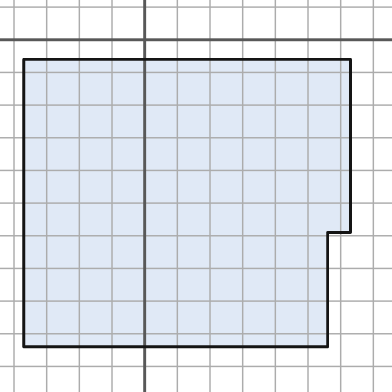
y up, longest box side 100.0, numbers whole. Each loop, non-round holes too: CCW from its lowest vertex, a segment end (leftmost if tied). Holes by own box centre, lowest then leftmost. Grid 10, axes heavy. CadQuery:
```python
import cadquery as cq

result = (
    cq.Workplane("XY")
    .moveTo(-37.0, -94.0)
    .lineTo(56.0, -94.0)
    .lineTo(56.0, -59.0)
    .lineTo(63.0, -59.0)
    .lineTo(63.0, -6.0)
    .lineTo(-37.0, -6.0)
    .close()
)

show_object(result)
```